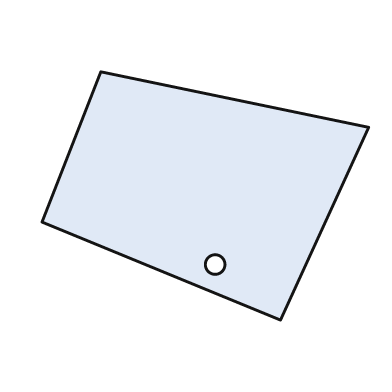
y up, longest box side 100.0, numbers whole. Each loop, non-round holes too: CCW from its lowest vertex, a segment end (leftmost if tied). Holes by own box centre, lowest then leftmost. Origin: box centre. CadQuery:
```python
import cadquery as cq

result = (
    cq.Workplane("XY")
    .moveTo(23.0, -38.0)
    .lineTo(50.0, 21.0)
    .lineTo(-32.0, 38.0)
    .lineTo(-50.0, -8.0)
    .close()
    .moveTo(3.0, -21.0)
    .circle(3.0)
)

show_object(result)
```